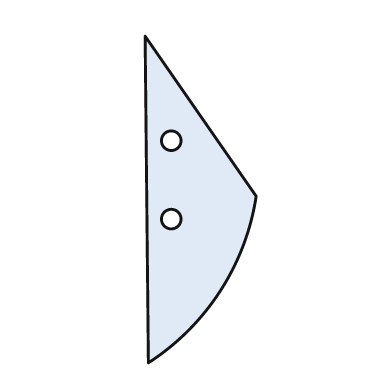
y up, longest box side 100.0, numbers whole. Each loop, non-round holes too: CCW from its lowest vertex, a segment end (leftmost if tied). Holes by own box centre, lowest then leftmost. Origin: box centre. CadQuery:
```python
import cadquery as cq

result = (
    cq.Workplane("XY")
    .moveTo(-16.0, -50.0)
    .threePointArc((6.0, -28.0), (17.0, 1.0))
    .lineTo(-17.0, 50.0)
    .close()
    .moveTo(-9.0, -6.0)
    .circle(3.0)
    .moveTo(-9.0, 18.0)
    .circle(3.0)
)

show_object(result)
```